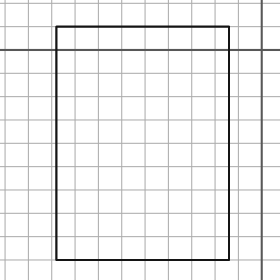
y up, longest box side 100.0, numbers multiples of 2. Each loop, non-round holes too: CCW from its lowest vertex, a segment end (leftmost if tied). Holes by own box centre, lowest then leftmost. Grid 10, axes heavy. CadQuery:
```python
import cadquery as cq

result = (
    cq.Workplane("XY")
    .moveTo(-88.0, -90.0)
    .lineTo(-14.0, -90.0)
    .lineTo(-14.0, 10.0)
    .lineTo(-88.0, 10.0)
    .close()
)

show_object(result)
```